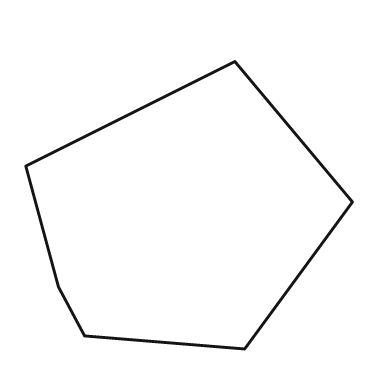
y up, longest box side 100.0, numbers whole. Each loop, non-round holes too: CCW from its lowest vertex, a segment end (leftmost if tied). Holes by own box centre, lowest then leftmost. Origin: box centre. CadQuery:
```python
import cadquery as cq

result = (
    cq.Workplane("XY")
    .moveTo(17.0, -44.0)
    .lineTo(50.0, 1.0)
    .lineTo(14.0, 44.0)
    .lineTo(-50.0, 12.0)
    .lineTo(-40.0, -25.0)
    .lineTo(-32.0, -40.0)
    .close()
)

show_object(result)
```